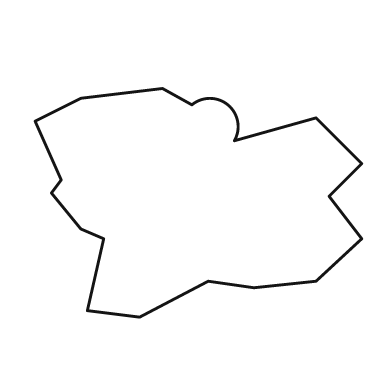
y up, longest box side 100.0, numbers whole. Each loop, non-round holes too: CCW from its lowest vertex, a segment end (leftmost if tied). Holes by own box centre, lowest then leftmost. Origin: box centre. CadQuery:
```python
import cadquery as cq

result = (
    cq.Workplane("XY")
    .moveTo(-18.0, -35.0)
    .lineTo(3.0, -24.0)
    .lineTo(17.0, -26.0)
    .lineTo(36.0, -24.0)
    .lineTo(50.0, -11.0)
    .lineTo(40.0, 2.0)
    .lineTo(50.0, 12.0)
    .lineTo(36.0, 26.0)
    .lineTo(11.0, 19.0)
    .threePointArc((9.0, 30.0), (-2.0, 30.0))
    .lineTo(-11.0, 35.0)
    .lineTo(-36.0, 32.0)
    .lineTo(-50.0, 25.0)
    .lineTo(-42.0, 7.0)
    .lineTo(-45.0, 3.0)
    .lineTo(-36.0, -8.0)
    .lineTo(-29.0, -11.0)
    .lineTo(-34.0, -33.0)
    .close()
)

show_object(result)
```